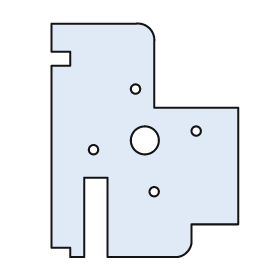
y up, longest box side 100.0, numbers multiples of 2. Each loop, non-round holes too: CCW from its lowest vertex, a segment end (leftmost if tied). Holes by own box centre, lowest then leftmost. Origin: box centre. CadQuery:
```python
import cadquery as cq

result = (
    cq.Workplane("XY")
    .moveTo(-32.0, -50.0)
    .lineTo(-26.0, -50.0)
    .lineTo(-26.0, -16.0)
    .lineTo(-16.0, -16.0)
    .lineTo(-16.0, -50.0)
    .lineTo(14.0, -50.0)
    .threePointArc((18.0, -48.0), (20.0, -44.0))
    .lineTo(20.0, -36.0)
    .lineTo(40.0, -36.0)
    .lineTo(40.0, 14.0)
    .lineTo(4.0, 14.0)
    .lineTo(4.0, 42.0)
    .threePointArc((2.0, 48.0), (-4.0, 50.0))
    .lineTo(-40.0, 50.0)
    .lineTo(-40.0, 38.0)
    .lineTo(-32.0, 38.0)
    .lineTo(-32.0, 32.0)
    .lineTo(-40.0, 32.0)
    .lineTo(-40.0, -46.0)
    .lineTo(-32.0, -46.0)
    .close()
    .moveTo(4.0, -22.0)
    .circle(2.0)
    .moveTo(-22.0, -4.0)
    .circle(2.0)
    .moveTo(0.0, 0.0)
    .circle(6.0)
    .moveTo(22.0, 4.0)
    .circle(2.0)
    .moveTo(-4.0, 22.0)
    .circle(2.0)
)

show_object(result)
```